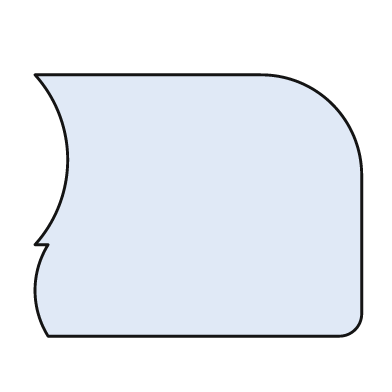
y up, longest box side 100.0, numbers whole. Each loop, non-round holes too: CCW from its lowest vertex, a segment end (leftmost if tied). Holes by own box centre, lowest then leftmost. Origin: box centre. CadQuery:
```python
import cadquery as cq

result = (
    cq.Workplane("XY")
    .moveTo(-46.0, -40.0)
    .lineTo(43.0, -40.0)
    .threePointArc((48.0, -38.0), (50.0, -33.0))
    .lineTo(50.0, 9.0)
    .threePointArc((41.0, 31.0), (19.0, 40.0))
    .lineTo(-50.0, 40.0)
    .threePointArc((-40.0, 14.0), (-50.0, -12.0))
    .lineTo(-46.0, -12.0)
    .threePointArc((-50.0, -26.0), (-46.0, -40.0))
    .close()
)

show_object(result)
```